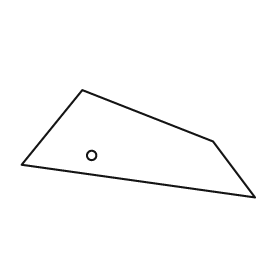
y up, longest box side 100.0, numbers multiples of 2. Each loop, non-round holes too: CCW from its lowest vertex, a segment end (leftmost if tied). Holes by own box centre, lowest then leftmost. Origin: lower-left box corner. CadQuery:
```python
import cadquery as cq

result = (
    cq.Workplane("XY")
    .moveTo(100.0, 0.0)
    .lineTo(82.0, 24.0)
    .lineTo(26.0, 46.0)
    .lineTo(0.0, 14.0)
    .close()
    .moveTo(30.0, 18.0)
    .circle(2.0)
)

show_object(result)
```